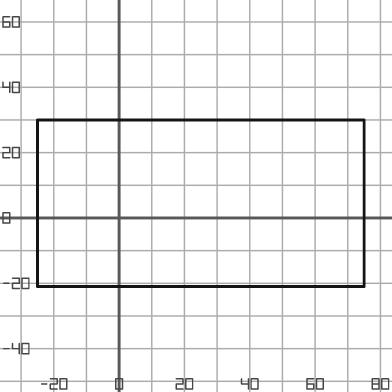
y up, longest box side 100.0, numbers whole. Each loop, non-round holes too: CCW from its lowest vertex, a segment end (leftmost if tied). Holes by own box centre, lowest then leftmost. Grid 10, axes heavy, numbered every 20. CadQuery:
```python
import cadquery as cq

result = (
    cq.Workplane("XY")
    .moveTo(-25.0, -21.0)
    .lineTo(75.0, -21.0)
    .lineTo(75.0, 30.0)
    .lineTo(-25.0, 30.0)
    .close()
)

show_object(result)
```